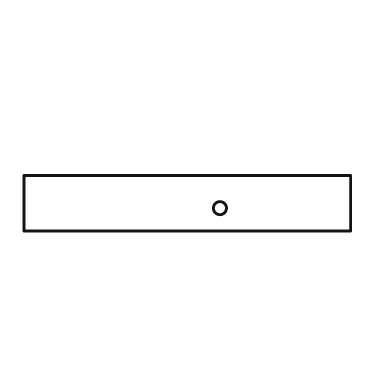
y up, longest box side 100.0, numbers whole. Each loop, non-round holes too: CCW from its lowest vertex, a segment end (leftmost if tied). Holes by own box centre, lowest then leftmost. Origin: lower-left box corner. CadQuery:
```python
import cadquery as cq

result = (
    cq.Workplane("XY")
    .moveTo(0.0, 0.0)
    .lineTo(100.0, 0.0)
    .lineTo(100.0, 17.0)
    .lineTo(0.0, 17.0)
    .close()
    .moveTo(60.0, 7.0)
    .circle(2.0)
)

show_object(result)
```